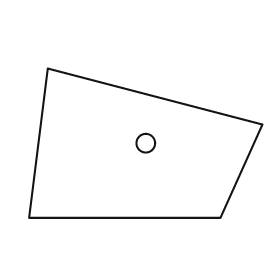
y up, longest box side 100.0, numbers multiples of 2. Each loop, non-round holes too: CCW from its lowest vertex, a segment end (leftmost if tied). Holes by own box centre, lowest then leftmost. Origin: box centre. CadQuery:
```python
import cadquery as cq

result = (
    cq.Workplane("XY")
    .moveTo(-50.0, -32.0)
    .lineTo(32.0, -32.0)
    .lineTo(50.0, 8.0)
    .lineTo(-42.0, 32.0)
    .close()
    .moveTo(0.0, 0.0)
    .circle(4.0)
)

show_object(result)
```